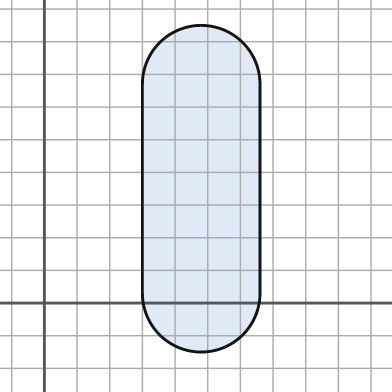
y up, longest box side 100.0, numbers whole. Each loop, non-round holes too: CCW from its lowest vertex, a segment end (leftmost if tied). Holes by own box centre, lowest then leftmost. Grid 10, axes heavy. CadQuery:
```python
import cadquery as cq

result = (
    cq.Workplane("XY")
    .moveTo(30.0, 3.0)
    .threePointArc((48.0, -15.0), (66.0, 3.0))
    .lineTo(66.0, 67.0)
    .threePointArc((48.0, 85.0), (30.0, 67.0))
    .close()
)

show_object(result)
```